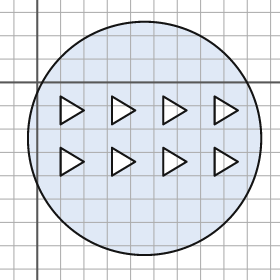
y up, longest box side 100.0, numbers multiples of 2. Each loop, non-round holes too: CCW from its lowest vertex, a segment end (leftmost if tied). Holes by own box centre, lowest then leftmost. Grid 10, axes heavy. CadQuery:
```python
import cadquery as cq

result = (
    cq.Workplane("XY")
    .moveTo(46.0, -24.0)
    .circle(50.0)
    .moveTo(10.0, -40.0)
    .lineTo(20.0, -34.0)
    .lineTo(10.0, -28.0)
    .close()
    .moveTo(32.0, -40.0)
    .lineTo(42.0, -34.0)
    .lineTo(32.0, -28.0)
    .close()
    .moveTo(54.0, -40.0)
    .lineTo(64.0, -34.0)
    .lineTo(54.0, -28.0)
    .close()
    .moveTo(76.0, -40.0)
    .lineTo(86.0, -34.0)
    .lineTo(76.0, -28.0)
    .close()
    .moveTo(10.0, -18.0)
    .lineTo(20.0, -12.0)
    .lineTo(10.0, -6.0)
    .close()
    .moveTo(32.0, -18.0)
    .lineTo(42.0, -12.0)
    .lineTo(32.0, -6.0)
    .close()
    .moveTo(54.0, -18.0)
    .lineTo(64.0, -12.0)
    .lineTo(54.0, -6.0)
    .close()
    .moveTo(76.0, -18.0)
    .lineTo(86.0, -12.0)
    .lineTo(76.0, -6.0)
    .close()
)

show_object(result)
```